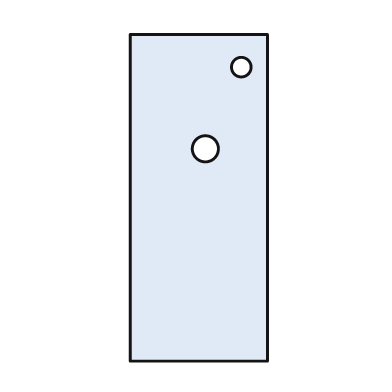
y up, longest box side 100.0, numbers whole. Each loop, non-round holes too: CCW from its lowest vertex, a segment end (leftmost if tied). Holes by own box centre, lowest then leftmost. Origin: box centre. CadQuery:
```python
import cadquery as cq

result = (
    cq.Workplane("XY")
    .moveTo(-21.0, -50.0)
    .lineTo(21.0, -50.0)
    .lineTo(21.0, 50.0)
    .lineTo(-21.0, 50.0)
    .close()
    .moveTo(2.0, 15.0)
    .circle(4.0)
    .moveTo(13.0, 40.0)
    .circle(3.0)
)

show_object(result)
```